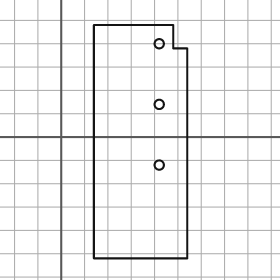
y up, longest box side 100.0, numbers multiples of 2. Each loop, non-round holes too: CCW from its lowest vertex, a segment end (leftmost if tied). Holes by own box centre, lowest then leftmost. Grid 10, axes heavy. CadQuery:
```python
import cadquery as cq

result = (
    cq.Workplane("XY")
    .moveTo(14.0, -52.0)
    .lineTo(54.0, -52.0)
    .lineTo(54.0, 38.0)
    .lineTo(48.0, 38.0)
    .lineTo(48.0, 48.0)
    .lineTo(14.0, 48.0)
    .close()
    .moveTo(42.0, -12.0)
    .circle(2.0)
    .moveTo(42.0, 14.0)
    .circle(2.0)
    .moveTo(42.0, 40.0)
    .circle(2.0)
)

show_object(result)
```